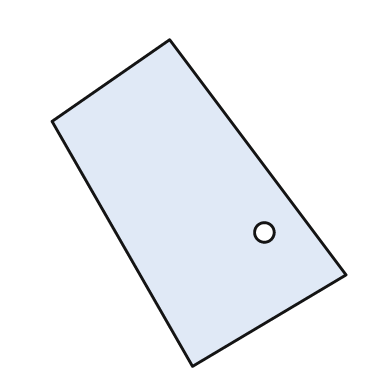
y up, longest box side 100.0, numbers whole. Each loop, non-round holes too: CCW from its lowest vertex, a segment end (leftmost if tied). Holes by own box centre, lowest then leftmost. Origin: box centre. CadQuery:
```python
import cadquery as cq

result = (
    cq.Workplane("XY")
    .moveTo(-2.0, -50.0)
    .lineTo(45.0, -22.0)
    .lineTo(-9.0, 50.0)
    .lineTo(-45.0, 25.0)
    .close()
    .moveTo(20.0, -9.0)
    .circle(3.0)
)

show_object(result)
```